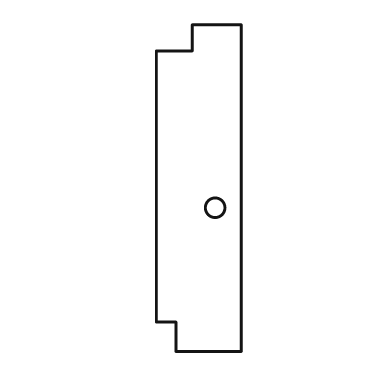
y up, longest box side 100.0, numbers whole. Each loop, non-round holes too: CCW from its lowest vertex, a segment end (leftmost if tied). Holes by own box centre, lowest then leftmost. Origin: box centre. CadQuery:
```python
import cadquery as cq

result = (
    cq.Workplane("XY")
    .moveTo(-7.0, -50.0)
    .lineTo(13.0, -50.0)
    .lineTo(13.0, 50.0)
    .lineTo(-2.0, 50.0)
    .lineTo(-2.0, 42.0)
    .lineTo(-13.0, 42.0)
    .lineTo(-13.0, -41.0)
    .lineTo(-7.0, -41.0)
    .close()
    .moveTo(5.0, -6.0)
    .circle(3.0)
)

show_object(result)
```